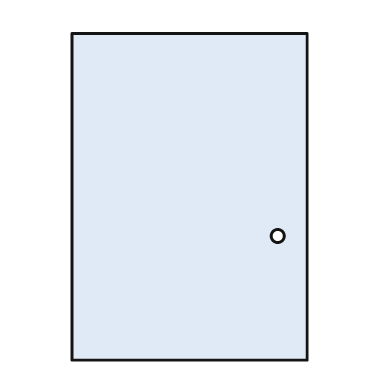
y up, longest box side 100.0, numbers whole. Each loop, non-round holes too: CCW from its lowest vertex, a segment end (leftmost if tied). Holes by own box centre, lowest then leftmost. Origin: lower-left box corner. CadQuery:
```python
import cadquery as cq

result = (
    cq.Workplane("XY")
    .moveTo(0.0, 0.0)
    .lineTo(72.0, 0.0)
    .lineTo(72.0, 100.0)
    .lineTo(0.0, 100.0)
    .close()
    .moveTo(63.0, 38.0)
    .circle(2.0)
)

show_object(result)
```